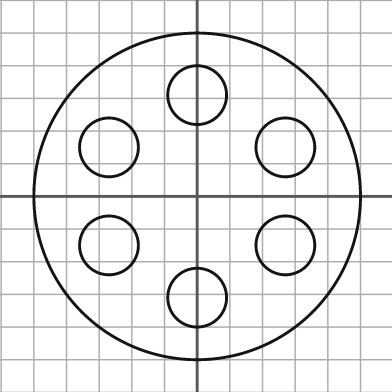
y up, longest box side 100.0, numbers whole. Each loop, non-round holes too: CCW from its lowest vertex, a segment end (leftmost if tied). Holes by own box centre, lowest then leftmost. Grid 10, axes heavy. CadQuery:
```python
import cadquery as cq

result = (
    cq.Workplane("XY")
    .moveTo(0.0, 0.0)
    .circle(50.0)
    .moveTo(0.0, -31.0)
    .circle(9.0)
    .moveTo(-27.0, -15.0)
    .circle(9.0)
    .moveTo(27.0, -15.0)
    .circle(9.0)
    .moveTo(-27.0, 15.0)
    .circle(9.0)
    .moveTo(27.0, 15.0)
    .circle(9.0)
    .moveTo(0.0, 31.0)
    .circle(9.0)
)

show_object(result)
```